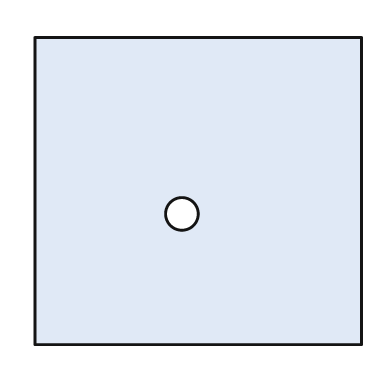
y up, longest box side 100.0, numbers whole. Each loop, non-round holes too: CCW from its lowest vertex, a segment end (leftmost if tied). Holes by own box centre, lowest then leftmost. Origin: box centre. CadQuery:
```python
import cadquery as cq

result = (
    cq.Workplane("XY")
    .moveTo(-50.0, -47.0)
    .lineTo(50.0, -47.0)
    .lineTo(50.0, 47.0)
    .lineTo(-50.0, 47.0)
    .close()
    .moveTo(-5.0, -7.0)
    .circle(5.0)
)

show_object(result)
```